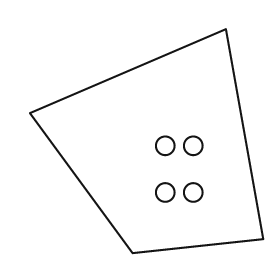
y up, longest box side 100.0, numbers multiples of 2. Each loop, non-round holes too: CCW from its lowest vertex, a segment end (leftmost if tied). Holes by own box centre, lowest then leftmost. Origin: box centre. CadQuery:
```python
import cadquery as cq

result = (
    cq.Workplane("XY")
    .moveTo(-6.0, -48.0)
    .lineTo(50.0, -42.0)
    .lineTo(34.0, 48.0)
    .lineTo(-50.0, 12.0)
    .close()
    .moveTo(8.0, -22.0)
    .circle(4.0)
    .moveTo(20.0, -22.0)
    .circle(4.0)
    .moveTo(8.0, -2.0)
    .circle(4.0)
    .moveTo(20.0, -2.0)
    .circle(4.0)
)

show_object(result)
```